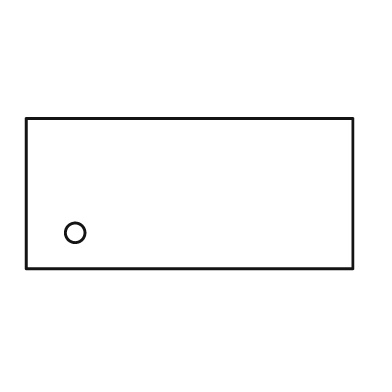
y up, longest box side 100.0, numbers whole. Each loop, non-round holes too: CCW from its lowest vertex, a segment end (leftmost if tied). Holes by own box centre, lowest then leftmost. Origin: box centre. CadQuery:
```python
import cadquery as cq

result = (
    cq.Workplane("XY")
    .moveTo(-50.0, -23.0)
    .lineTo(50.0, -23.0)
    .lineTo(50.0, 23.0)
    .lineTo(-50.0, 23.0)
    .close()
    .moveTo(-35.0, -12.0)
    .circle(3.0)
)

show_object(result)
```